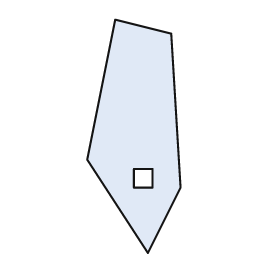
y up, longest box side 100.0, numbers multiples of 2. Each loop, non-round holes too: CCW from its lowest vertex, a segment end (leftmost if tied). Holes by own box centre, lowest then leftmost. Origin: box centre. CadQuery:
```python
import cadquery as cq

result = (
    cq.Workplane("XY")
    .moveTo(6.0, -50.0)
    .lineTo(20.0, -22.0)
    .lineTo(16.0, 44.0)
    .lineTo(-8.0, 50.0)
    .lineTo(-20.0, -10.0)
    .close()
    .moveTo(0.0, -22.0)
    .lineTo(8.0, -22.0)
    .lineTo(8.0, -14.0)
    .lineTo(0.0, -14.0)
    .close()
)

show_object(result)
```